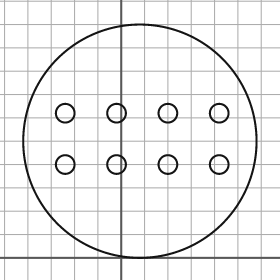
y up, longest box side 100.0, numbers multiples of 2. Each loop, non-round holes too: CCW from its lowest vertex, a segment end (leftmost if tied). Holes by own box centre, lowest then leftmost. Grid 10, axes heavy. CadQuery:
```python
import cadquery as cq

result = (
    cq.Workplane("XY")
    .moveTo(8.0, 50.0)
    .circle(50.0)
    .moveTo(-24.0, 40.0)
    .circle(4.0)
    .moveTo(-2.0, 40.0)
    .circle(4.0)
    .moveTo(20.0, 40.0)
    .circle(4.0)
    .moveTo(42.0, 40.0)
    .circle(4.0)
    .moveTo(-24.0, 62.0)
    .circle(4.0)
    .moveTo(-2.0, 62.0)
    .circle(4.0)
    .moveTo(20.0, 62.0)
    .circle(4.0)
    .moveTo(42.0, 62.0)
    .circle(4.0)
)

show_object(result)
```